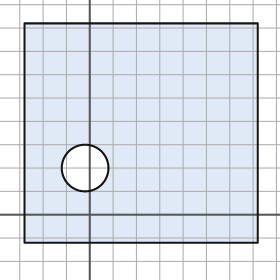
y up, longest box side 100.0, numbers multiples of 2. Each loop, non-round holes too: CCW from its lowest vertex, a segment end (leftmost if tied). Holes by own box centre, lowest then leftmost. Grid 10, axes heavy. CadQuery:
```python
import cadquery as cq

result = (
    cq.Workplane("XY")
    .moveTo(-28.0, -12.0)
    .lineTo(72.0, -12.0)
    .lineTo(72.0, 82.0)
    .lineTo(-28.0, 82.0)
    .close()
    .moveTo(-2.0, 20.0)
    .circle(10.0)
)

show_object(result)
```